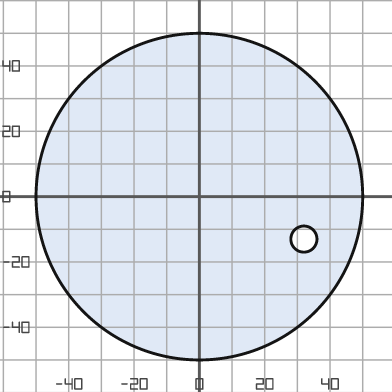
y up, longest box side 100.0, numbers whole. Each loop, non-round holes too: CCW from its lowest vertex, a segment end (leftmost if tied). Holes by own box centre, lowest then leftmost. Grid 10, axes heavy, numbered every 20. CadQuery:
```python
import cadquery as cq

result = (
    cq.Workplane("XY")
    .moveTo(0.0, 0.0)
    .circle(50.0)
    .moveTo(32.0, -13.0)
    .circle(4.0)
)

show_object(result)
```